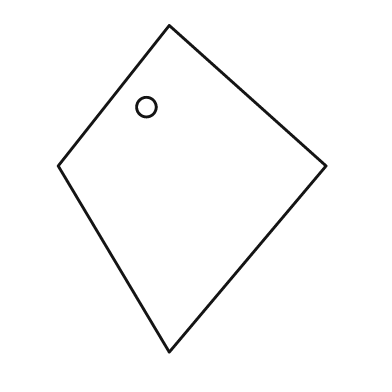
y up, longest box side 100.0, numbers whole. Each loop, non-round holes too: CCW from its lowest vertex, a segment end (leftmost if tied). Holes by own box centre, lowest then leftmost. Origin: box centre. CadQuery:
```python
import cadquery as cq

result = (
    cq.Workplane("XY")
    .moveTo(-7.0, -50.0)
    .lineTo(41.0, 7.0)
    .lineTo(-7.0, 50.0)
    .lineTo(-41.0, 7.0)
    .close()
    .moveTo(-14.0, 25.0)
    .circle(3.0)
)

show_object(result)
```